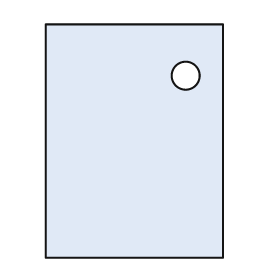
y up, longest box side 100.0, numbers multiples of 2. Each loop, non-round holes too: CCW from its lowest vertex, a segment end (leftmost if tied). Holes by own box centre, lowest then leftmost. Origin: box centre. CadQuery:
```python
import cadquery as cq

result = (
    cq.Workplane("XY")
    .moveTo(-38.0, -50.0)
    .lineTo(38.0, -50.0)
    .lineTo(38.0, 50.0)
    .lineTo(-38.0, 50.0)
    .close()
    .moveTo(22.0, 28.0)
    .circle(6.0)
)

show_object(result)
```